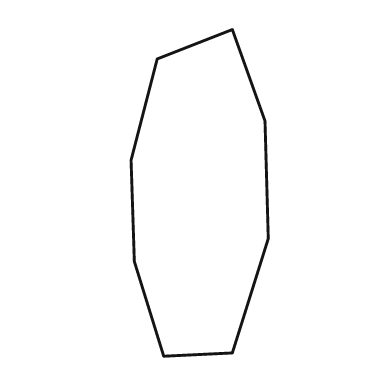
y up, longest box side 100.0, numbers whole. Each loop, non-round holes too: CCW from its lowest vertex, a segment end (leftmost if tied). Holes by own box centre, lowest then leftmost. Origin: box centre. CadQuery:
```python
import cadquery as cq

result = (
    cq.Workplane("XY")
    .moveTo(-11.0, -50.0)
    .lineTo(10.0, -49.0)
    .lineTo(21.0, -14.0)
    .lineTo(20.0, 22.0)
    .lineTo(10.0, 50.0)
    .lineTo(-13.0, 41.0)
    .lineTo(-21.0, 10.0)
    .lineTo(-20.0, -21.0)
    .close()
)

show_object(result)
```